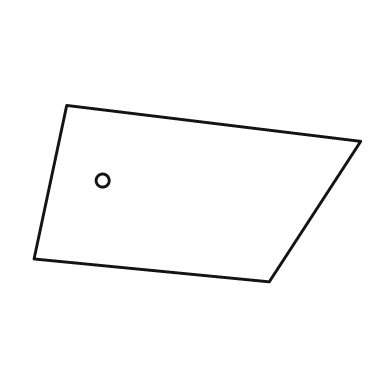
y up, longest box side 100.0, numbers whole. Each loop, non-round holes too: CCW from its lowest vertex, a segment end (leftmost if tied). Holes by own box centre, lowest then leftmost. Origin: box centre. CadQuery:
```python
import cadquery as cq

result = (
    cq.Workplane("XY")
    .moveTo(22.0, -27.0)
    .lineTo(50.0, 16.0)
    .lineTo(-40.0, 27.0)
    .lineTo(-50.0, -20.0)
    .close()
    .moveTo(-29.0, 4.0)
    .circle(2.0)
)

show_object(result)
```